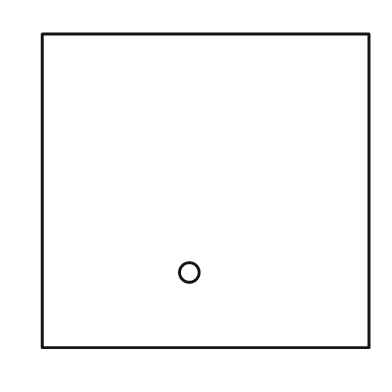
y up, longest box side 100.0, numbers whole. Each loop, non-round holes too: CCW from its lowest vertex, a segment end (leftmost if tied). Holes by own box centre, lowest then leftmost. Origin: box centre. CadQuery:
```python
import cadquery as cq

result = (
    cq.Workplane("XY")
    .moveTo(-50.0, -48.0)
    .lineTo(50.0, -48.0)
    .lineTo(50.0, 48.0)
    .lineTo(-50.0, 48.0)
    .close()
    .moveTo(-5.0, -25.0)
    .circle(3.0)
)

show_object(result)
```